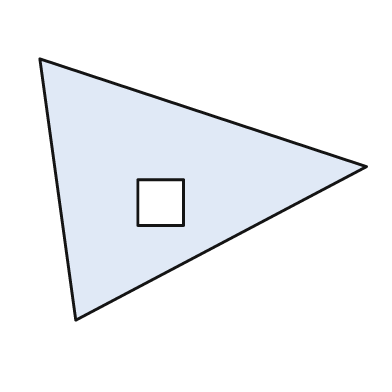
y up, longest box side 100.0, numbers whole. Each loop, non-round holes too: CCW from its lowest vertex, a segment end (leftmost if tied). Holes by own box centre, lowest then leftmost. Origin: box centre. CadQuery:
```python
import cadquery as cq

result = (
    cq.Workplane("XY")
    .moveTo(-39.0, -40.0)
    .lineTo(50.0, 7.0)
    .lineTo(-50.0, 40.0)
    .close()
    .moveTo(-20.0, -11.0)
    .lineTo(-6.0, -11.0)
    .lineTo(-6.0, 3.0)
    .lineTo(-20.0, 3.0)
    .close()
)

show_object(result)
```